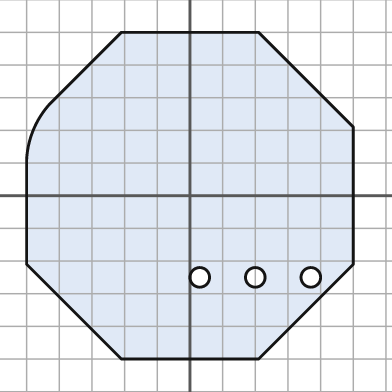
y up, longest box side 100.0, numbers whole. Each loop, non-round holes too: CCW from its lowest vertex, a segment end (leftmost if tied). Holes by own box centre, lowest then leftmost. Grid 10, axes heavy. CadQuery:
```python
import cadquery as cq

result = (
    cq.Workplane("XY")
    .moveTo(-21.0, -50.0)
    .lineTo(21.0, -50.0)
    .lineTo(50.0, -21.0)
    .lineTo(50.0, 21.0)
    .lineTo(21.0, 50.0)
    .lineTo(-21.0, 50.0)
    .lineTo(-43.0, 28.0)
    .threePointArc((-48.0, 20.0), (-50.0, 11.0))
    .lineTo(-50.0, -21.0)
    .close()
    .moveTo(3.0, -25.0)
    .circle(3.0)
    .moveTo(20.0, -25.0)
    .circle(3.0)
    .moveTo(37.0, -25.0)
    .circle(3.0)
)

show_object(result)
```